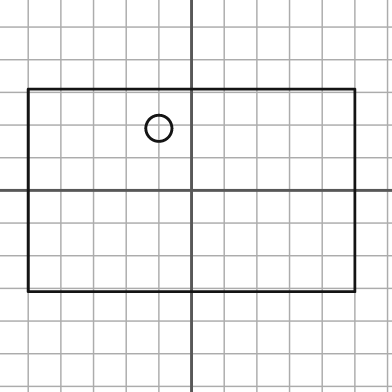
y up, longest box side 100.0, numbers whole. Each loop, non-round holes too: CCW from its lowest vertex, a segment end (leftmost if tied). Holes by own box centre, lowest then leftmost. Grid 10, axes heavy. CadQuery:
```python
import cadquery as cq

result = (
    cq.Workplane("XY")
    .moveTo(-50.0, -31.0)
    .lineTo(50.0, -31.0)
    .lineTo(50.0, 31.0)
    .lineTo(-50.0, 31.0)
    .close()
    .moveTo(-10.0, 19.0)
    .circle(4.0)
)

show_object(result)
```